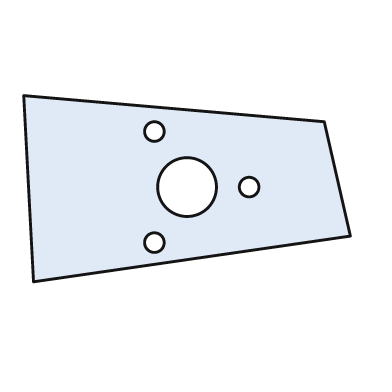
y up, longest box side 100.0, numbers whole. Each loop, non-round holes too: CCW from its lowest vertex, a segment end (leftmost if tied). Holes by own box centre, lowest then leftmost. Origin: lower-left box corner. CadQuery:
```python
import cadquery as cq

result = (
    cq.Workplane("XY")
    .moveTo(3.0, 0.0)
    .lineTo(100.0, 14.0)
    .lineTo(92.0, 49.0)
    .lineTo(0.0, 57.0)
    .close()
    .moveTo(40.0, 12.0)
    .circle(3.0)
    .moveTo(50.0, 29.0)
    .circle(9.0)
    .moveTo(69.0, 29.0)
    .circle(3.0)
    .moveTo(40.0, 46.0)
    .circle(3.0)
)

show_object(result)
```